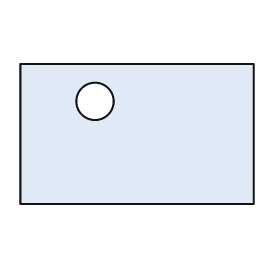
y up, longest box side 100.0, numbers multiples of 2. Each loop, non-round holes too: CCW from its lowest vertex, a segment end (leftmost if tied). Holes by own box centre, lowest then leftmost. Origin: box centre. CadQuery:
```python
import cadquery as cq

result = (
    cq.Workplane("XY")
    .moveTo(-50.0, -30.0)
    .lineTo(50.0, -30.0)
    .lineTo(50.0, 30.0)
    .lineTo(-50.0, 30.0)
    .close()
    .moveTo(-18.0, 14.0)
    .circle(8.0)
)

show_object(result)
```